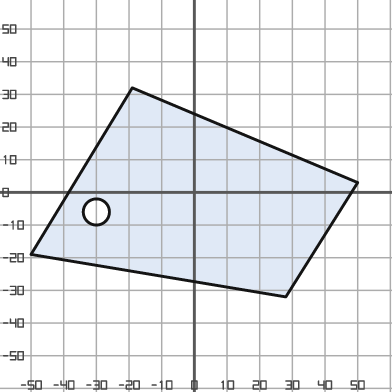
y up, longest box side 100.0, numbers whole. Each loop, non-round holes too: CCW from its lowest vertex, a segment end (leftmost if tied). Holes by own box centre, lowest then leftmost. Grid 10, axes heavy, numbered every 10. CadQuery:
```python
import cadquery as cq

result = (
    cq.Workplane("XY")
    .moveTo(28.0, -32.0)
    .lineTo(50.0, 3.0)
    .lineTo(-19.0, 32.0)
    .lineTo(-50.0, -19.0)
    .close()
    .moveTo(-30.0, -6.0)
    .circle(4.0)
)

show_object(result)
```